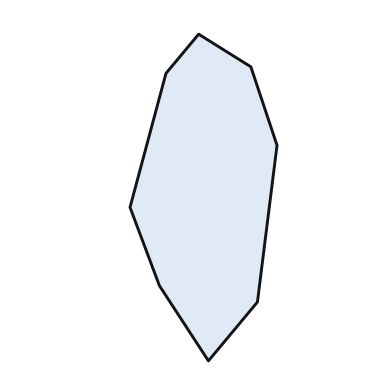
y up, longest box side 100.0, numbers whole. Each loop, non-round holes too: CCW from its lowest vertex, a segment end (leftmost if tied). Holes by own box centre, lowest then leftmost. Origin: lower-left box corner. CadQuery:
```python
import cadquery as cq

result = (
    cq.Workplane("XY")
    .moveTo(24.0, 0.0)
    .lineTo(39.0, 18.0)
    .lineTo(45.0, 66.0)
    .lineTo(37.0, 90.0)
    .lineTo(21.0, 100.0)
    .lineTo(11.0, 88.0)
    .lineTo(0.0, 47.0)
    .lineTo(9.0, 23.0)
    .close()
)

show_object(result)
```